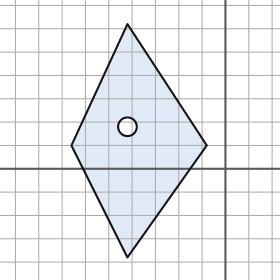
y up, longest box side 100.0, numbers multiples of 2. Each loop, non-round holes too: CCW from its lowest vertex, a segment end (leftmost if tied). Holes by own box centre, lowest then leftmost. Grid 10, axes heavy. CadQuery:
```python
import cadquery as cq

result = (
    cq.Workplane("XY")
    .moveTo(-42.0, -38.0)
    .lineTo(-8.0, 10.0)
    .lineTo(-42.0, 62.0)
    .lineTo(-66.0, 10.0)
    .close()
    .moveTo(-42.0, 18.0)
    .circle(4.0)
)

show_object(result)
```